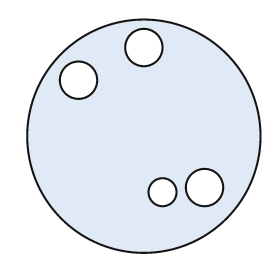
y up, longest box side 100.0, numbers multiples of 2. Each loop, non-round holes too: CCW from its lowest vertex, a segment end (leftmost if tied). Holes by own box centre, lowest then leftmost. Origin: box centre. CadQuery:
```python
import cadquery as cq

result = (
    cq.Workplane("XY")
    .moveTo(0.0, 0.0)
    .circle(50.0)
    .moveTo(8.0, -24.0)
    .circle(6.0)
    .moveTo(26.0, -22.0)
    .circle(8.0)
    .moveTo(-28.0, 24.0)
    .circle(8.0)
    .moveTo(0.0, 38.0)
    .circle(8.0)
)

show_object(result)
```